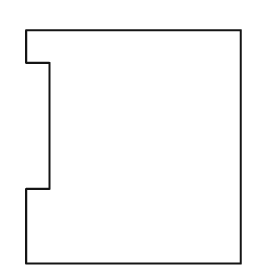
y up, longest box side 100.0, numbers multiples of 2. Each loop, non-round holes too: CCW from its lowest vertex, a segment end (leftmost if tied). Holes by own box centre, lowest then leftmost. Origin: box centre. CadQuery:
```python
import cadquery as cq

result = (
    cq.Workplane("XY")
    .moveTo(-46.0, -50.0)
    .lineTo(46.0, -50.0)
    .lineTo(46.0, 50.0)
    .lineTo(-46.0, 50.0)
    .lineTo(-46.0, 36.0)
    .lineTo(-36.0, 36.0)
    .lineTo(-36.0, -18.0)
    .lineTo(-46.0, -18.0)
    .close()
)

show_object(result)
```